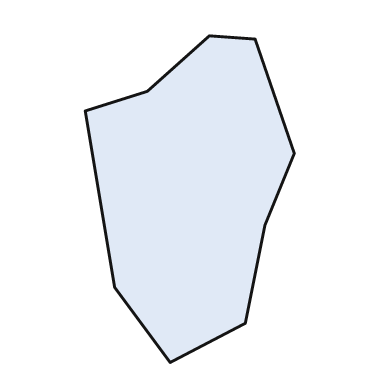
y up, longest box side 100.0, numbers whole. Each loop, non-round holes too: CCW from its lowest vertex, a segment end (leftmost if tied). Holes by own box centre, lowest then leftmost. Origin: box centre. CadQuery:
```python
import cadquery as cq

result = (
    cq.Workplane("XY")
    .moveTo(-6.0, -50.0)
    .lineTo(17.0, -38.0)
    .lineTo(23.0, -8.0)
    .lineTo(32.0, 14.0)
    .lineTo(20.0, 49.0)
    .lineTo(6.0, 50.0)
    .lineTo(-13.0, 33.0)
    .lineTo(-32.0, 27.0)
    .lineTo(-23.0, -27.0)
    .close()
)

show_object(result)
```